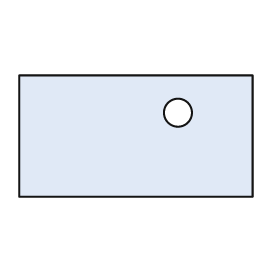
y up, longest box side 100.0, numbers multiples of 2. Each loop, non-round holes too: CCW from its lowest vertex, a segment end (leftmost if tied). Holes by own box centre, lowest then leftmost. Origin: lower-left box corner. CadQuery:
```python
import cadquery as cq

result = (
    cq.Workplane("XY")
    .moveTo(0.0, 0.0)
    .lineTo(100.0, 0.0)
    .lineTo(100.0, 52.0)
    .lineTo(0.0, 52.0)
    .close()
    .moveTo(68.0, 36.0)
    .circle(6.0)
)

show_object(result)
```